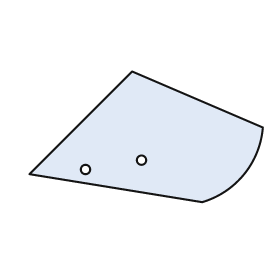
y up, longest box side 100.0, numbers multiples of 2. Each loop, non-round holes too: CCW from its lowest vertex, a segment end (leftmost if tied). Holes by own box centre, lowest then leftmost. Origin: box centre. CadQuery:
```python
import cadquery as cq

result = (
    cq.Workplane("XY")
    .moveTo(24.0, -28.0)
    .threePointArc((42.0, -16.0), (50.0, 4.0))
    .lineTo(-6.0, 28.0)
    .lineTo(-50.0, -16.0)
    .close()
    .moveTo(-26.0, -14.0)
    .circle(2.0)
    .moveTo(-2.0, -10.0)
    .circle(2.0)
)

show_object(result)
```